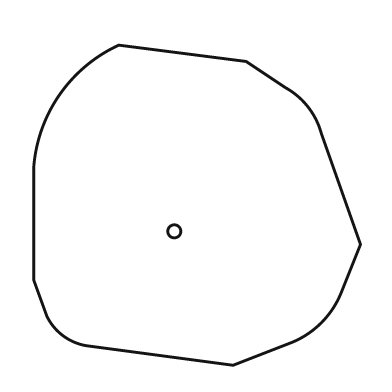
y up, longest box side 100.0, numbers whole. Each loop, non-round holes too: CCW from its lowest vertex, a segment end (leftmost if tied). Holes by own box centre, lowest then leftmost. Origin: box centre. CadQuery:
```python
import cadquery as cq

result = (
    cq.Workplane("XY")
    .moveTo(11.0, -49.0)
    .lineTo(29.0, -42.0)
    .threePointArc((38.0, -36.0), (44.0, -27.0))
    .lineTo(50.0, -12.0)
    .lineTo(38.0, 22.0)
    .threePointArc((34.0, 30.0), (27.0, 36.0))
    .lineTo(15.0, 44.0)
    .lineTo(-24.0, 49.0)
    .threePointArc((-42.0, 34.0), (-50.0, 12.0))
    .lineTo(-50.0, -23.0)
    .lineTo(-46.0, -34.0)
    .threePointArc((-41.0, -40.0), (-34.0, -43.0))
    .close()
    .moveTo(-7.0, -8.0)
    .circle(2.0)
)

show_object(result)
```